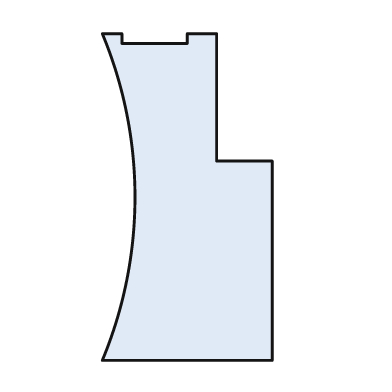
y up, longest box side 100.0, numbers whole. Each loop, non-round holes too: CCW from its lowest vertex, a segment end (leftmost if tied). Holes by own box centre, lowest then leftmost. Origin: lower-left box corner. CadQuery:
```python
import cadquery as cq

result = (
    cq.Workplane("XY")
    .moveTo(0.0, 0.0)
    .lineTo(52.0, 0.0)
    .lineTo(52.0, 61.0)
    .lineTo(35.0, 61.0)
    .lineTo(35.0, 100.0)
    .lineTo(26.0, 100.0)
    .lineTo(26.0, 97.0)
    .lineTo(6.0, 97.0)
    .lineTo(6.0, 100.0)
    .lineTo(0.0, 100.0)
    .threePointArc((10.0, 50.0), (0.0, 0.0))
    .close()
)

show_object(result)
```